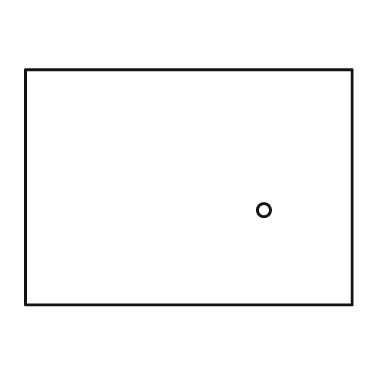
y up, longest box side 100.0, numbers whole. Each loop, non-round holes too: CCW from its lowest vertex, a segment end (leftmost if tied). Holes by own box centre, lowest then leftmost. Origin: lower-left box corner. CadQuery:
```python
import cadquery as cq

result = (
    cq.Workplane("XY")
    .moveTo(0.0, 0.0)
    .lineTo(100.0, 0.0)
    .lineTo(100.0, 72.0)
    .lineTo(0.0, 72.0)
    .close()
    .moveTo(73.0, 29.0)
    .circle(2.0)
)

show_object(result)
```